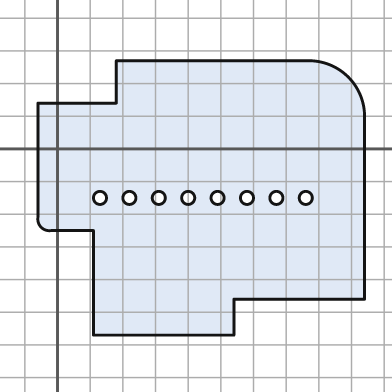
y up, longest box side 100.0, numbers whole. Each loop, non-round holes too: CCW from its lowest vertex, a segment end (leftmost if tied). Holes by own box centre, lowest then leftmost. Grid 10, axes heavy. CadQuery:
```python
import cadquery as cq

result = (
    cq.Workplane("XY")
    .moveTo(11.0, -57.0)
    .lineTo(54.0, -57.0)
    .lineTo(54.0, -46.0)
    .lineTo(94.0, -46.0)
    .lineTo(94.0, 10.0)
    .threePointArc((89.0, 22.0), (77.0, 27.0))
    .lineTo(18.0, 27.0)
    .lineTo(18.0, 14.0)
    .lineTo(-6.0, 14.0)
    .lineTo(-6.0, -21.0)
    .threePointArc((-5.0, -24.0), (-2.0, -25.0))
    .lineTo(11.0, -25.0)
    .close()
    .moveTo(13.0, -15.0)
    .circle(2.0)
    .moveTo(22.0, -15.0)
    .circle(2.0)
    .moveTo(31.0, -15.0)
    .circle(2.0)
    .moveTo(40.0, -15.0)
    .circle(2.0)
    .moveTo(49.0, -15.0)
    .circle(2.0)
    .moveTo(58.0, -15.0)
    .circle(2.0)
    .moveTo(67.0, -15.0)
    .circle(2.0)
    .moveTo(76.0, -15.0)
    .circle(2.0)
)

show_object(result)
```